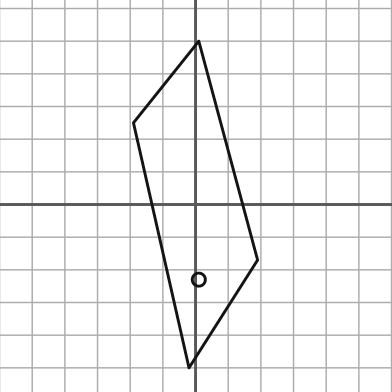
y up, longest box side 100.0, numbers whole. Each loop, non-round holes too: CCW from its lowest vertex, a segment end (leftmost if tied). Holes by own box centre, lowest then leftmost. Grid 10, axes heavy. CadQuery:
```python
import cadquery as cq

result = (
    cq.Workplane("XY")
    .moveTo(-2.0, -50.0)
    .lineTo(19.0, -17.0)
    .lineTo(1.0, 50.0)
    .lineTo(-19.0, 25.0)
    .close()
    .moveTo(1.0, -23.0)
    .circle(2.0)
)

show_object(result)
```